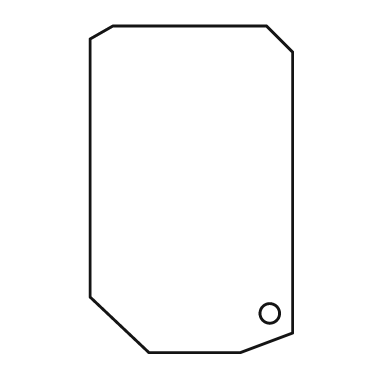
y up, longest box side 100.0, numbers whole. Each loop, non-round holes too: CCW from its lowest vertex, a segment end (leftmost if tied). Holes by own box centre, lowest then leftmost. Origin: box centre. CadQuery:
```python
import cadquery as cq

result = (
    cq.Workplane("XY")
    .moveTo(-13.0, -50.0)
    .lineTo(15.0, -50.0)
    .lineTo(31.0, -44.0)
    .lineTo(31.0, 42.0)
    .lineTo(23.0, 50.0)
    .lineTo(-24.0, 50.0)
    .lineTo(-31.0, 46.0)
    .lineTo(-31.0, -33.0)
    .close()
    .moveTo(24.0, -38.0)
    .circle(3.0)
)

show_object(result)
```